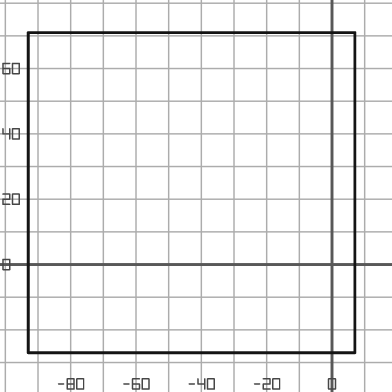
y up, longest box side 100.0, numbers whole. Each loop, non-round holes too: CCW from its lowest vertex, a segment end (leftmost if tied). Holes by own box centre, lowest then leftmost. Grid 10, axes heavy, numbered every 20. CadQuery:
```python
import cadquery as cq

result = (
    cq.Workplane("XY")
    .moveTo(-93.0, -27.0)
    .lineTo(7.0, -27.0)
    .lineTo(7.0, 71.0)
    .lineTo(-93.0, 71.0)
    .close()
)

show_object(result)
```